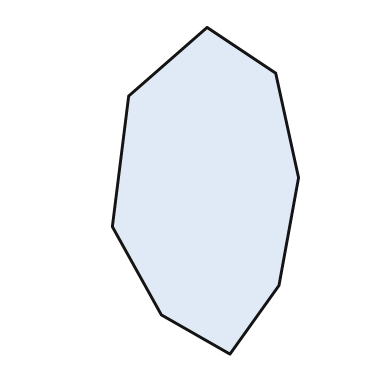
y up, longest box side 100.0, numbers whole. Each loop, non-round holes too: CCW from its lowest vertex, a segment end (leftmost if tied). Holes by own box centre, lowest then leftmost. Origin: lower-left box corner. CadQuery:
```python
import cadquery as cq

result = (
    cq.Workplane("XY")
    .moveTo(36.0, 0.0)
    .lineTo(51.0, 21.0)
    .lineTo(57.0, 54.0)
    .lineTo(50.0, 86.0)
    .lineTo(29.0, 100.0)
    .lineTo(5.0, 79.0)
    .lineTo(0.0, 39.0)
    .lineTo(15.0, 12.0)
    .close()
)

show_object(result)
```